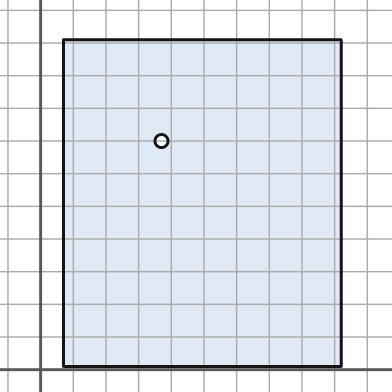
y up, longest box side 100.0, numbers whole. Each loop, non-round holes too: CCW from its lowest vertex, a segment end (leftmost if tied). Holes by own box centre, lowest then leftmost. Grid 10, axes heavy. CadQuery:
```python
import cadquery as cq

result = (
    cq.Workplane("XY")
    .moveTo(7.0, 1.0)
    .lineTo(92.0, 1.0)
    .lineTo(92.0, 101.0)
    .lineTo(7.0, 101.0)
    .close()
    .moveTo(37.0, 70.0)
    .circle(2.0)
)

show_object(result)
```